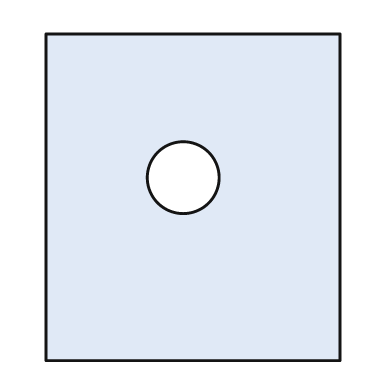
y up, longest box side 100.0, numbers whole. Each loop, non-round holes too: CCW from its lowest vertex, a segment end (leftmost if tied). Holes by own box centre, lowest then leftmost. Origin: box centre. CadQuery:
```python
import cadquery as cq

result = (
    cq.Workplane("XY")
    .moveTo(-45.0, -50.0)
    .lineTo(45.0, -50.0)
    .lineTo(45.0, 50.0)
    .lineTo(-45.0, 50.0)
    .close()
    .moveTo(-3.0, 6.0)
    .circle(11.0)
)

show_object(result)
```